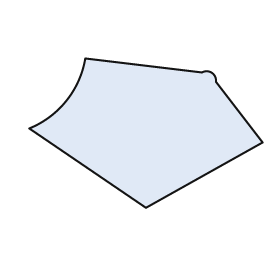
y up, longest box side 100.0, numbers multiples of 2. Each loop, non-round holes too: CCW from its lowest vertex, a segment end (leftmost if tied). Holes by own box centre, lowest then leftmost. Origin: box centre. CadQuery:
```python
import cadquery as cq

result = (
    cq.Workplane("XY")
    .moveTo(0.0, -32.0)
    .lineTo(50.0, -4.0)
    .lineTo(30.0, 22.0)
    .threePointArc((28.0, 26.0), (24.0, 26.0))
    .lineTo(-26.0, 32.0)
    .threePointArc((-34.0, 14.0), (-50.0, 2.0))
    .close()
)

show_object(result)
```